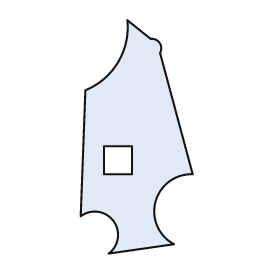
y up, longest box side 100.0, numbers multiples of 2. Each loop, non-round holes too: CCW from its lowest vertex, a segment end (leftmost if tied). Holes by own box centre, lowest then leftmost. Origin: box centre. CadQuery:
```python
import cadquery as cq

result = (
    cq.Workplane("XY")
    .moveTo(-12.0, -50.0)
    .lineTo(16.0, -46.0)
    .threePointArc((8.0, -28.0), (24.0, -16.0))
    .lineTo(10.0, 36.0)
    .threePointArc((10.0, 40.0), (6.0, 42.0))
    .lineTo(-4.0, 50.0)
    .threePointArc((-8.0, 32.0), (-22.0, 20.0))
    .lineTo(-24.0, -34.0)
    .threePointArc((-10.0, -36.0), (-12.0, -50.0))
    .close()
    .moveTo(-14.0, -16.0)
    .lineTo(-2.0, -16.0)
    .lineTo(-2.0, -4.0)
    .lineTo(-14.0, -4.0)
    .close()
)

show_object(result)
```